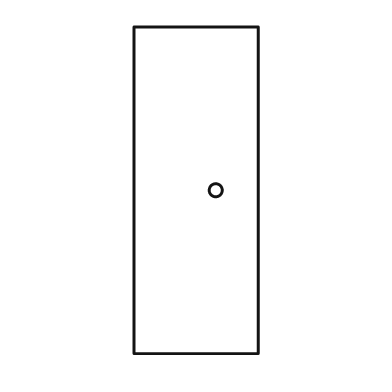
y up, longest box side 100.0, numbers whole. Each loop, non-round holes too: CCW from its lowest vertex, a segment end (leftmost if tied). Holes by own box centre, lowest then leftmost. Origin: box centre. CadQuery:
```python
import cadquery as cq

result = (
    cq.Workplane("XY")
    .moveTo(-19.0, -50.0)
    .lineTo(19.0, -50.0)
    .lineTo(19.0, 50.0)
    .lineTo(-19.0, 50.0)
    .close()
    .moveTo(6.0, 0.0)
    .circle(2.0)
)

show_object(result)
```